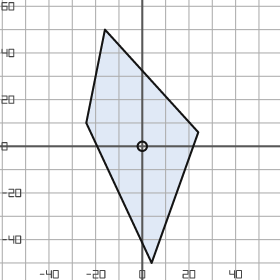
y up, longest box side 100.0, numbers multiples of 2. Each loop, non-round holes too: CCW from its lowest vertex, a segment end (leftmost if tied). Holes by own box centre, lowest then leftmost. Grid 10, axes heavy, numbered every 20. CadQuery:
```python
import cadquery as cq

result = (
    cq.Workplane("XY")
    .moveTo(4.0, -50.0)
    .lineTo(24.0, 6.0)
    .lineTo(-16.0, 50.0)
    .lineTo(-24.0, 10.0)
    .close()
    .moveTo(0.0, 0.0)
    .circle(2.0)
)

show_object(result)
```